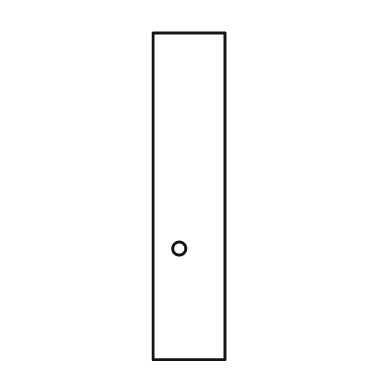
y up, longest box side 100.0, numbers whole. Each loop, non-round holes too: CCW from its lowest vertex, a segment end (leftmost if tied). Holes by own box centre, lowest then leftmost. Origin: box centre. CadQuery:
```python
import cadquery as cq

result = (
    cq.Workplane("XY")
    .moveTo(-11.0, -50.0)
    .lineTo(11.0, -50.0)
    .lineTo(11.0, 50.0)
    .lineTo(-11.0, 50.0)
    .close()
    .moveTo(-3.0, -16.0)
    .circle(2.0)
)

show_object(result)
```